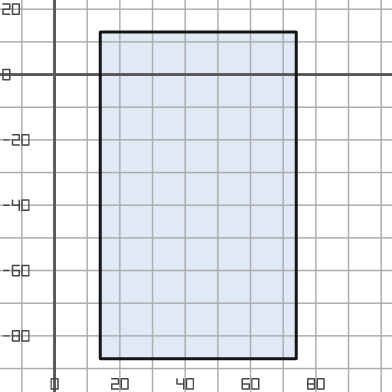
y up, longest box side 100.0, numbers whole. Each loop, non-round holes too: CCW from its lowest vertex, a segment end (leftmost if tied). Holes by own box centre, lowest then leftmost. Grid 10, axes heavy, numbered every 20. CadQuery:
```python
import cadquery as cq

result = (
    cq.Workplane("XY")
    .moveTo(14.0, -87.0)
    .lineTo(74.0, -87.0)
    .lineTo(74.0, 13.0)
    .lineTo(14.0, 13.0)
    .close()
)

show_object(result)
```